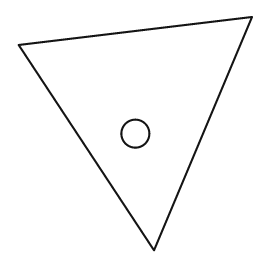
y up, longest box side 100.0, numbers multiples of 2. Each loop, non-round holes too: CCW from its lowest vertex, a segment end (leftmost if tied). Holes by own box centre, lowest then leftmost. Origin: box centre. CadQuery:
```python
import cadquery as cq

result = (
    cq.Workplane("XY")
    .moveTo(8.0, -50.0)
    .lineTo(50.0, 50.0)
    .lineTo(-50.0, 38.0)
    .close()
    .moveTo(0.0, 0.0)
    .circle(6.0)
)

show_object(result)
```